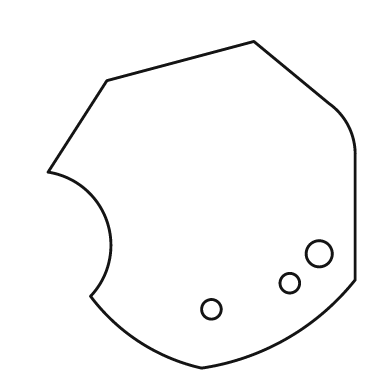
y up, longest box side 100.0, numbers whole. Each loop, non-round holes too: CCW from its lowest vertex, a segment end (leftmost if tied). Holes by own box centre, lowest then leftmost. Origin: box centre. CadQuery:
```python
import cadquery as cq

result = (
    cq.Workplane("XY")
    .moveTo(0.0, -50.0)
    .threePointArc((26.0, -41.0), (47.0, -23.0))
    .lineTo(47.0, 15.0)
    .threePointArc((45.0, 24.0), (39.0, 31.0))
    .lineTo(16.0, 50.0)
    .lineTo(-29.0, 38.0)
    .lineTo(-47.0, 10.0)
    .threePointArc((-29.0, -5.0), (-34.0, -28.0))
    .threePointArc((-19.0, -42.0), (0.0, -50.0))
    .close()
    .moveTo(3.0, -32.0)
    .circle(3.0)
    .moveTo(27.0, -24.0)
    .circle(3.0)
    .moveTo(36.0, -15.0)
    .circle(4.0)
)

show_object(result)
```